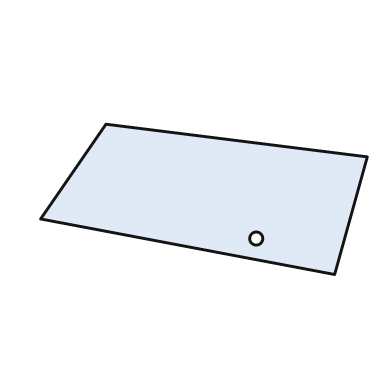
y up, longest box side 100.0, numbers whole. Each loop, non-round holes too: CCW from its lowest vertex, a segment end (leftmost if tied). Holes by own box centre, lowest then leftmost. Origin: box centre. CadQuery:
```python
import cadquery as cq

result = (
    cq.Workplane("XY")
    .moveTo(40.0, -23.0)
    .lineTo(50.0, 13.0)
    .lineTo(-30.0, 23.0)
    .lineTo(-50.0, -6.0)
    .close()
    .moveTo(16.0, -12.0)
    .circle(2.0)
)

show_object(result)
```